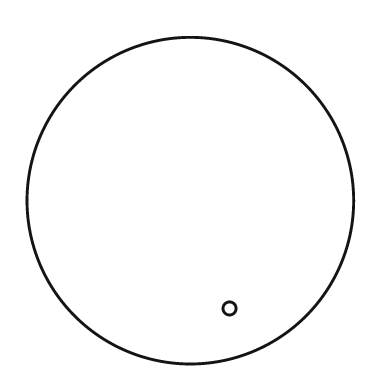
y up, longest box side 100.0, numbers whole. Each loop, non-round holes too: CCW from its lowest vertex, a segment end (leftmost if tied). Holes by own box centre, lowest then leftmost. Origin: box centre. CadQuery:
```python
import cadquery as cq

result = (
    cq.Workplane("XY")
    .moveTo(0.0, 0.0)
    .circle(50.0)
    .moveTo(12.0, -33.0)
    .circle(2.0)
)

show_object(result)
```